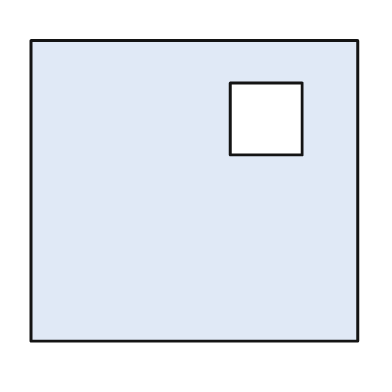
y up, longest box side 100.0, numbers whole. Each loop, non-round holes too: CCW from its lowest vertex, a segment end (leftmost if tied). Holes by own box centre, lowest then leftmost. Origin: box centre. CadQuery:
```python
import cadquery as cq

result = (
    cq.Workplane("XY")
    .moveTo(-50.0, -46.0)
    .lineTo(50.0, -46.0)
    .lineTo(50.0, 46.0)
    .lineTo(-50.0, 46.0)
    .close()
    .moveTo(11.0, 11.0)
    .lineTo(33.0, 11.0)
    .lineTo(33.0, 33.0)
    .lineTo(11.0, 33.0)
    .close()
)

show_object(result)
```